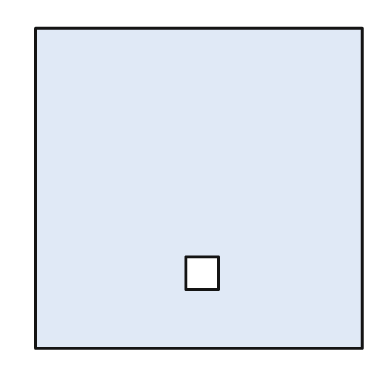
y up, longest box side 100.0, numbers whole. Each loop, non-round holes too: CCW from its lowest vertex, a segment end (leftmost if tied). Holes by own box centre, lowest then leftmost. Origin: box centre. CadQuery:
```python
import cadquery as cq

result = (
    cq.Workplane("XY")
    .moveTo(-50.0, -49.0)
    .lineTo(50.0, -49.0)
    .lineTo(50.0, 49.0)
    .lineTo(-50.0, 49.0)
    .close()
    .moveTo(-4.0, -31.0)
    .lineTo(6.0, -31.0)
    .lineTo(6.0, -21.0)
    .lineTo(-4.0, -21.0)
    .close()
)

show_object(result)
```